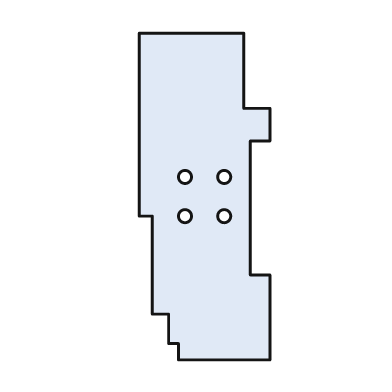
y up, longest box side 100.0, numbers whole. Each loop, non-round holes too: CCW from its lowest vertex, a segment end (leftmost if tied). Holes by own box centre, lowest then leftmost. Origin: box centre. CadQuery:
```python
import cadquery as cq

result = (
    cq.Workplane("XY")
    .moveTo(-8.0, -50.0)
    .lineTo(20.0, -50.0)
    .lineTo(20.0, -24.0)
    .lineTo(14.0, -24.0)
    .lineTo(14.0, 17.0)
    .lineTo(20.0, 17.0)
    .lineTo(20.0, 27.0)
    .lineTo(12.0, 27.0)
    .lineTo(12.0, 50.0)
    .lineTo(-20.0, 50.0)
    .lineTo(-20.0, -6.0)
    .lineTo(-16.0, -6.0)
    .lineTo(-16.0, -36.0)
    .lineTo(-11.0, -36.0)
    .lineTo(-11.0, -45.0)
    .lineTo(-8.0, -45.0)
    .close()
    .moveTo(-6.0, -6.0)
    .circle(2.0)
    .moveTo(6.0, -6.0)
    .circle(2.0)
    .moveTo(-6.0, 6.0)
    .circle(2.0)
    .moveTo(6.0, 6.0)
    .circle(2.0)
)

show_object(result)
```